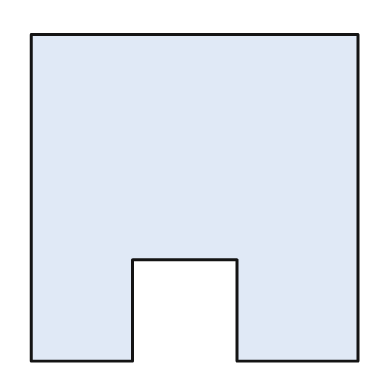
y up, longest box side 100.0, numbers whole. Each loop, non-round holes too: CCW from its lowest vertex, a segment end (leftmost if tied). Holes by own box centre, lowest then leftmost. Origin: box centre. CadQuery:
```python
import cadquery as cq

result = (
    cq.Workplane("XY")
    .moveTo(-50.0, -50.0)
    .lineTo(-19.0, -50.0)
    .lineTo(-19.0, -19.0)
    .lineTo(13.0, -19.0)
    .lineTo(13.0, -50.0)
    .lineTo(50.0, -50.0)
    .lineTo(50.0, 50.0)
    .lineTo(-50.0, 50.0)
    .close()
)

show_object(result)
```